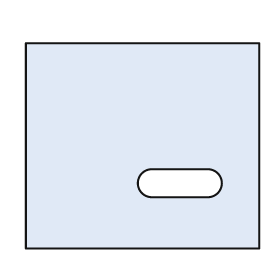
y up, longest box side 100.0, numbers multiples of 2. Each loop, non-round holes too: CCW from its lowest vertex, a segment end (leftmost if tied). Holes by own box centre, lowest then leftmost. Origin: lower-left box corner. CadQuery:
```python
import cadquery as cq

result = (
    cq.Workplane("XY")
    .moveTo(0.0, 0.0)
    .lineTo(100.0, 0.0)
    .lineTo(100.0, 88.0)
    .lineTo(0.0, 88.0)
    .close()
    .moveTo(54.0, 22.0)
    .lineTo(78.0, 22.0)
    .threePointArc((84.0, 28.0), (78.0, 34.0))
    .lineTo(54.0, 34.0)
    .threePointArc((48.0, 28.0), (54.0, 22.0))
    .close()
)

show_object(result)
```